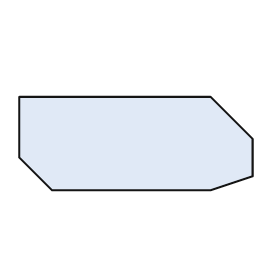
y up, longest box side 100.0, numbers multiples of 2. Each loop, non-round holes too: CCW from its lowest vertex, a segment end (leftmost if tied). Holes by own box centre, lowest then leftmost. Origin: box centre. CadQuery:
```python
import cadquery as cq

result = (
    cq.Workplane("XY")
    .moveTo(-36.0, -20.0)
    .lineTo(32.0, -20.0)
    .lineTo(50.0, -14.0)
    .lineTo(50.0, 2.0)
    .lineTo(32.0, 20.0)
    .lineTo(-50.0, 20.0)
    .lineTo(-50.0, -6.0)
    .close()
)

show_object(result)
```